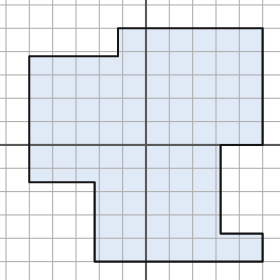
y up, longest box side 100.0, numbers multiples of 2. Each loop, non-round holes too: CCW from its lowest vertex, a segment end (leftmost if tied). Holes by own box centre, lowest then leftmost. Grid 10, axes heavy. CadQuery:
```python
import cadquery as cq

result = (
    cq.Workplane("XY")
    .moveTo(-22.0, -50.0)
    .lineTo(50.0, -50.0)
    .lineTo(50.0, -38.0)
    .lineTo(32.0, -38.0)
    .lineTo(32.0, 0.0)
    .lineTo(50.0, 0.0)
    .lineTo(50.0, 50.0)
    .lineTo(-12.0, 50.0)
    .lineTo(-12.0, 38.0)
    .lineTo(-50.0, 38.0)
    .lineTo(-50.0, -16.0)
    .lineTo(-22.0, -16.0)
    .close()
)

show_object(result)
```